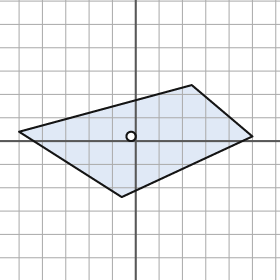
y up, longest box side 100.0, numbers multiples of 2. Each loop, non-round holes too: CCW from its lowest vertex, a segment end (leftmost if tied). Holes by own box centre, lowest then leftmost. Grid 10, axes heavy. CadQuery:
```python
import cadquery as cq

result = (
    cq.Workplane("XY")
    .moveTo(-6.0, -24.0)
    .lineTo(50.0, 2.0)
    .lineTo(24.0, 24.0)
    .lineTo(-50.0, 4.0)
    .close()
    .moveTo(-2.0, 2.0)
    .circle(2.0)
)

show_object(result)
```